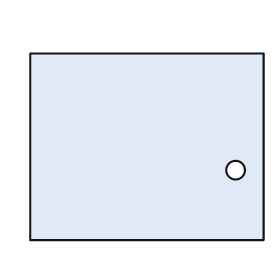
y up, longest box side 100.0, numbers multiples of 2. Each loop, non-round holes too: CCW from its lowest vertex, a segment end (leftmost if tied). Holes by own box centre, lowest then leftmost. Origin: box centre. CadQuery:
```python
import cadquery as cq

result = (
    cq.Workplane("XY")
    .moveTo(-50.0, -40.0)
    .lineTo(50.0, -40.0)
    .lineTo(50.0, 40.0)
    .lineTo(-50.0, 40.0)
    .close()
    .moveTo(38.0, -10.0)
    .circle(4.0)
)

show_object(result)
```